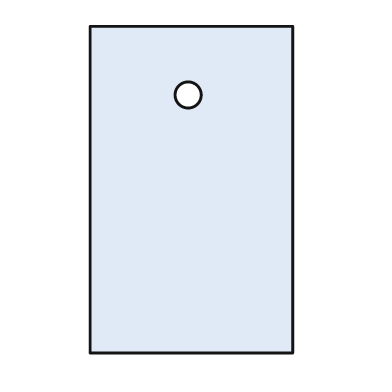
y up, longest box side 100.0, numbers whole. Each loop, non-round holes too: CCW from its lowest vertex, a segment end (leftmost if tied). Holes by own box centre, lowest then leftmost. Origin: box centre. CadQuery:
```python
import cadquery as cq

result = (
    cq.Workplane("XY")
    .moveTo(-31.0, -50.0)
    .lineTo(31.0, -50.0)
    .lineTo(31.0, 50.0)
    .lineTo(-31.0, 50.0)
    .close()
    .moveTo(-1.0, 29.0)
    .circle(4.0)
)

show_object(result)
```